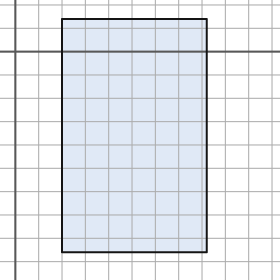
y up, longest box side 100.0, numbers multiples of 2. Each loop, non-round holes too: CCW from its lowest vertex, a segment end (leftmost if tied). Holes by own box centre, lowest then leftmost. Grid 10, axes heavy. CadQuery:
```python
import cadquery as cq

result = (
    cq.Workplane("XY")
    .moveTo(20.0, -86.0)
    .lineTo(82.0, -86.0)
    .lineTo(82.0, 14.0)
    .lineTo(20.0, 14.0)
    .close()
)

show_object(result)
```